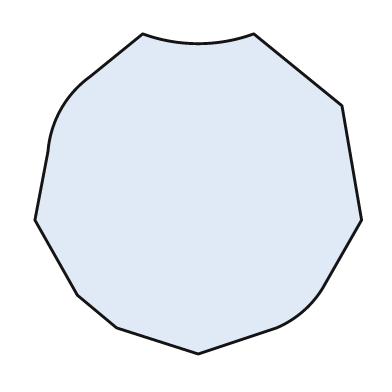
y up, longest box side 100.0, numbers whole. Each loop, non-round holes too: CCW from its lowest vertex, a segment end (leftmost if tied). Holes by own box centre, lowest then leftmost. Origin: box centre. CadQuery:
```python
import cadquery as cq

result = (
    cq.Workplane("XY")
    .moveTo(0.0, -49.0)
    .lineTo(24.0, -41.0)
    .threePointArc((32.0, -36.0), (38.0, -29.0))
    .lineTo(50.0, -8.0)
    .lineTo(44.0, 27.0)
    .lineTo(17.0, 49.0)
    .threePointArc((0.0, 46.0), (-17.0, 49.0))
    .lineTo(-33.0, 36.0)
    .threePointArc((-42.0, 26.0), (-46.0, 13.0))
    .lineTo(-50.0, -8.0)
    .lineTo(-37.0, -31.0)
    .lineTo(-25.0, -41.0)
    .close()
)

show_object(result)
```